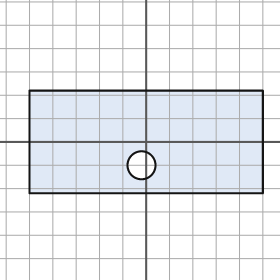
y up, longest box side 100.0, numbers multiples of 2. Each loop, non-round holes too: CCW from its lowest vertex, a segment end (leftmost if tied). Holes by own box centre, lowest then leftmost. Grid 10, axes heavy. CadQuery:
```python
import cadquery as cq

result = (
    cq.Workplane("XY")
    .moveTo(-50.0, -22.0)
    .lineTo(50.0, -22.0)
    .lineTo(50.0, 22.0)
    .lineTo(-50.0, 22.0)
    .close()
    .moveTo(-2.0, -10.0)
    .circle(6.0)
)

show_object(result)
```